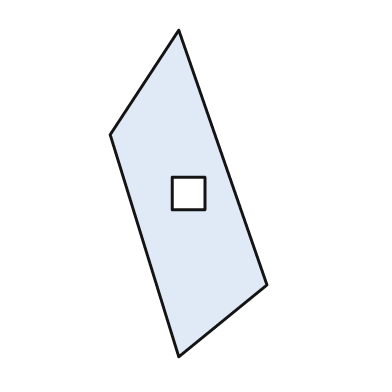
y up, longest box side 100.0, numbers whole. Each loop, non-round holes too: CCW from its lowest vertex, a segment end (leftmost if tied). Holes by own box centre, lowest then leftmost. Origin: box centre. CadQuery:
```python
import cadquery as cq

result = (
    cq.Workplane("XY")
    .moveTo(-3.0, -50.0)
    .lineTo(24.0, -28.0)
    .lineTo(-3.0, 50.0)
    .lineTo(-24.0, 18.0)
    .close()
    .moveTo(-5.0, -5.0)
    .lineTo(5.0, -5.0)
    .lineTo(5.0, 5.0)
    .lineTo(-5.0, 5.0)
    .close()
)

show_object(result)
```